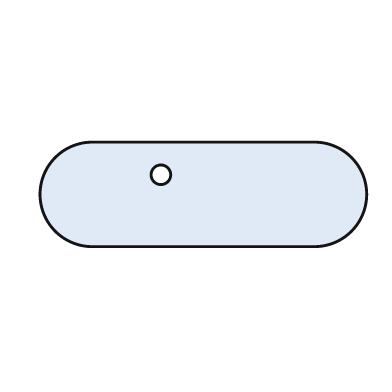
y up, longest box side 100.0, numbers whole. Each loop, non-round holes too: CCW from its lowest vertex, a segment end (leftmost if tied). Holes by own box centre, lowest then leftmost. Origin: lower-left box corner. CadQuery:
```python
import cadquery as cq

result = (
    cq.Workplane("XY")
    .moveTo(16.0, 0.0)
    .lineTo(84.0, 0.0)
    .threePointArc((100.0, 16.0), (84.0, 32.0))
    .lineTo(16.0, 32.0)
    .threePointArc((0.0, 16.0), (16.0, 0.0))
    .close()
    .moveTo(37.0, 22.0)
    .circle(3.0)
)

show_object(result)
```